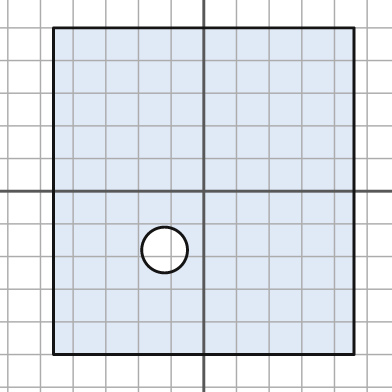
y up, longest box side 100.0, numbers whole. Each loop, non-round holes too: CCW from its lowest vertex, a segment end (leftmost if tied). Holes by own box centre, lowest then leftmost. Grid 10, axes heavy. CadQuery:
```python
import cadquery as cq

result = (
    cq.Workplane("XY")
    .moveTo(-46.0, -50.0)
    .lineTo(46.0, -50.0)
    .lineTo(46.0, 50.0)
    .lineTo(-46.0, 50.0)
    .close()
    .moveTo(-12.0, -18.0)
    .circle(7.0)
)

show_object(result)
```